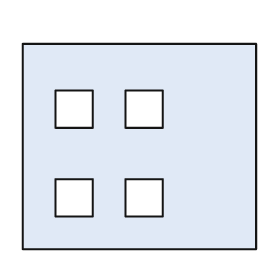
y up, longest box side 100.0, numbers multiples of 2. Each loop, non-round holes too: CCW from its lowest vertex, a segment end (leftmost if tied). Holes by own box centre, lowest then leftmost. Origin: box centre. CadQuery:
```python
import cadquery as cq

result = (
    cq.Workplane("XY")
    .moveTo(-50.0, -44.0)
    .lineTo(50.0, -44.0)
    .lineTo(50.0, 44.0)
    .lineTo(-50.0, 44.0)
    .close()
    .moveTo(-36.0, -30.0)
    .lineTo(-20.0, -30.0)
    .lineTo(-20.0, -14.0)
    .lineTo(-36.0, -14.0)
    .close()
    .moveTo(-6.0, -30.0)
    .lineTo(10.0, -30.0)
    .lineTo(10.0, -14.0)
    .lineTo(-6.0, -14.0)
    .close()
    .moveTo(-36.0, 8.0)
    .lineTo(-20.0, 8.0)
    .lineTo(-20.0, 24.0)
    .lineTo(-36.0, 24.0)
    .close()
    .moveTo(-6.0, 8.0)
    .lineTo(10.0, 8.0)
    .lineTo(10.0, 24.0)
    .lineTo(-6.0, 24.0)
    .close()
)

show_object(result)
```